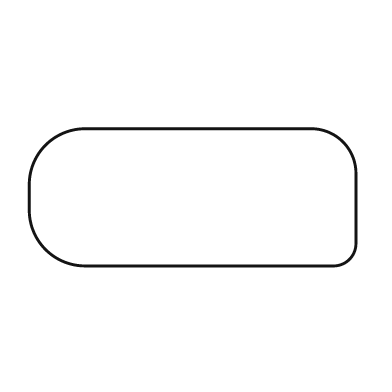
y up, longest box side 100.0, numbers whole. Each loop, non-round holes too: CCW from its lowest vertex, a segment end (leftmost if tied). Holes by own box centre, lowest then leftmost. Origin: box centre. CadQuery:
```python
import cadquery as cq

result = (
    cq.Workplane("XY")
    .moveTo(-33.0, -21.0)
    .lineTo(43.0, -21.0)
    .threePointArc((48.0, -19.0), (50.0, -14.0))
    .lineTo(50.0, 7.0)
    .threePointArc((46.0, 17.0), (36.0, 21.0))
    .lineTo(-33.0, 21.0)
    .threePointArc((-45.0, 16.0), (-50.0, 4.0))
    .lineTo(-50.0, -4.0)
    .threePointArc((-45.0, -16.0), (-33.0, -21.0))
    .close()
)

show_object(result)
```